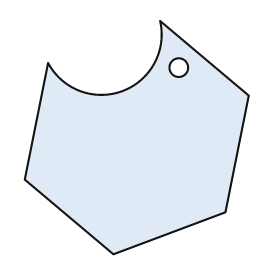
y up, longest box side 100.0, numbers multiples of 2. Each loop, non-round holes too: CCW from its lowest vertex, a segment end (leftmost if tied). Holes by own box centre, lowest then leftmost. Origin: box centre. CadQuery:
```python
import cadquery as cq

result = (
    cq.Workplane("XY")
    .moveTo(-10.0, -50.0)
    .lineTo(38.0, -32.0)
    .lineTo(48.0, 18.0)
    .lineTo(10.0, 50.0)
    .threePointArc((-6.0, 20.0), (-38.0, 32.0))
    .lineTo(-48.0, -18.0)
    .close()
    .moveTo(18.0, 30.0)
    .circle(4.0)
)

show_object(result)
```